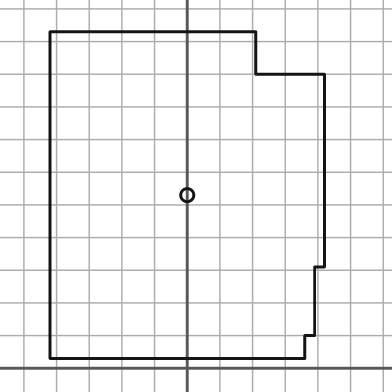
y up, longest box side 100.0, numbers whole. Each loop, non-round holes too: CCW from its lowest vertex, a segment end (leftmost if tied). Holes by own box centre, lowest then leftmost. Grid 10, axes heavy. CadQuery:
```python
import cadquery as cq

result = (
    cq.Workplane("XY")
    .moveTo(-42.0, 3.0)
    .lineTo(36.0, 3.0)
    .lineTo(36.0, 10.0)
    .lineTo(39.0, 10.0)
    .lineTo(39.0, 31.0)
    .lineTo(42.0, 31.0)
    .lineTo(42.0, 90.0)
    .lineTo(21.0, 90.0)
    .lineTo(21.0, 103.0)
    .lineTo(-42.0, 103.0)
    .close()
    .moveTo(0.0, 53.0)
    .circle(2.0)
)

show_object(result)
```